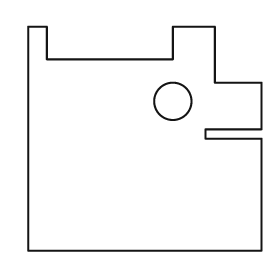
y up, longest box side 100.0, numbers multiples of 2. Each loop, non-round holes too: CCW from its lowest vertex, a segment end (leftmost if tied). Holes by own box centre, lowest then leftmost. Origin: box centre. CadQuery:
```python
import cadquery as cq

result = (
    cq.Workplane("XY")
    .moveTo(-50.0, -48.0)
    .lineTo(50.0, -48.0)
    .lineTo(50.0, 0.0)
    .lineTo(26.0, 0.0)
    .lineTo(26.0, 4.0)
    .lineTo(50.0, 4.0)
    .lineTo(50.0, 24.0)
    .lineTo(30.0, 24.0)
    .lineTo(30.0, 48.0)
    .lineTo(12.0, 48.0)
    .lineTo(12.0, 34.0)
    .lineTo(-42.0, 34.0)
    .lineTo(-42.0, 48.0)
    .lineTo(-50.0, 48.0)
    .close()
    .moveTo(12.0, 16.0)
    .circle(8.0)
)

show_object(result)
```